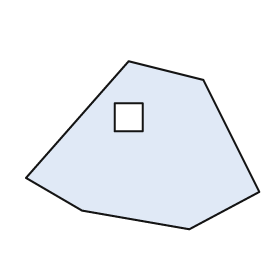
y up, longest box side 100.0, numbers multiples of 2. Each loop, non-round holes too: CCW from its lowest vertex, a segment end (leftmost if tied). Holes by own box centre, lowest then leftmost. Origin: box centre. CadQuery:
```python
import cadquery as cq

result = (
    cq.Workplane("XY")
    .moveTo(20.0, -36.0)
    .lineTo(50.0, -20.0)
    .lineTo(26.0, 28.0)
    .lineTo(-6.0, 36.0)
    .lineTo(-50.0, -14.0)
    .lineTo(-26.0, -28.0)
    .close()
    .moveTo(-12.0, 6.0)
    .lineTo(0.0, 6.0)
    .lineTo(0.0, 18.0)
    .lineTo(-12.0, 18.0)
    .close()
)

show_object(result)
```